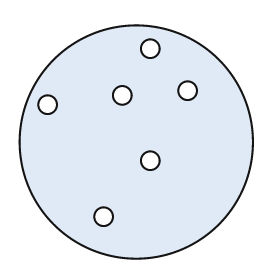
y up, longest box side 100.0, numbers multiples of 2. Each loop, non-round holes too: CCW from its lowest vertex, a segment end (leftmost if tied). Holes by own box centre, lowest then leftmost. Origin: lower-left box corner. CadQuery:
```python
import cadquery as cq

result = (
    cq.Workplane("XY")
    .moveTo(50.0, 50.0)
    .circle(50.0)
    .moveTo(36.0, 18.0)
    .circle(4.0)
    .moveTo(56.0, 42.0)
    .circle(4.0)
    .moveTo(12.0, 66.0)
    .circle(4.0)
    .moveTo(44.0, 70.0)
    .circle(4.0)
    .moveTo(72.0, 72.0)
    .circle(4.0)
    .moveTo(56.0, 90.0)
    .circle(4.0)
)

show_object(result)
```